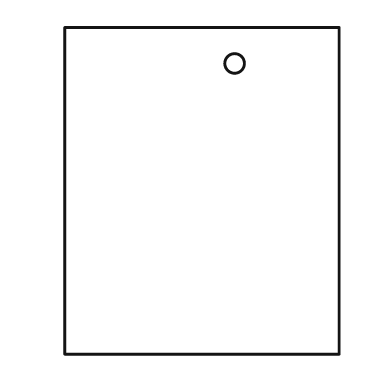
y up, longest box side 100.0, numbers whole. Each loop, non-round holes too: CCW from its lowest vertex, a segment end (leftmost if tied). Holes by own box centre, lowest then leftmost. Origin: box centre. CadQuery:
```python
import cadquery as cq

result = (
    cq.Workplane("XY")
    .moveTo(-42.0, -50.0)
    .lineTo(42.0, -50.0)
    .lineTo(42.0, 50.0)
    .lineTo(-42.0, 50.0)
    .close()
    .moveTo(10.0, 39.0)
    .circle(3.0)
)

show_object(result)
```